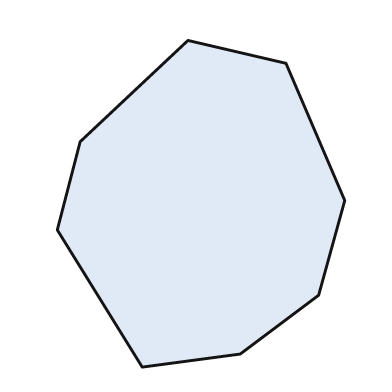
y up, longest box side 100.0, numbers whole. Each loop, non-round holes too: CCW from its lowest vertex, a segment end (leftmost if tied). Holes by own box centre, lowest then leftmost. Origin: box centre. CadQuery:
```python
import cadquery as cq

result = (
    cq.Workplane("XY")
    .moveTo(-18.0, -50.0)
    .lineTo(12.0, -46.0)
    .lineTo(36.0, -28.0)
    .lineTo(44.0, 1.0)
    .lineTo(26.0, 43.0)
    .lineTo(-4.0, 50.0)
    .lineTo(-37.0, 19.0)
    .lineTo(-44.0, -8.0)
    .close()
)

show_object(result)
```